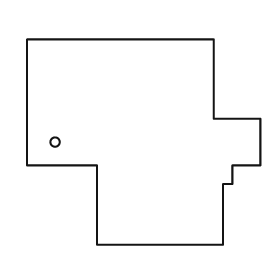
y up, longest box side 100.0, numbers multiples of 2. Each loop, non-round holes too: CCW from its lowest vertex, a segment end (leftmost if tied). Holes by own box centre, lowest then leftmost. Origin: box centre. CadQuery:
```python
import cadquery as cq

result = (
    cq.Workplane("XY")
    .moveTo(-20.0, -44.0)
    .lineTo(34.0, -44.0)
    .lineTo(34.0, -18.0)
    .lineTo(38.0, -18.0)
    .lineTo(38.0, -10.0)
    .lineTo(50.0, -10.0)
    .lineTo(50.0, 10.0)
    .lineTo(30.0, 10.0)
    .lineTo(30.0, 44.0)
    .lineTo(-50.0, 44.0)
    .lineTo(-50.0, -10.0)
    .lineTo(-20.0, -10.0)
    .close()
    .moveTo(-38.0, 0.0)
    .circle(2.0)
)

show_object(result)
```